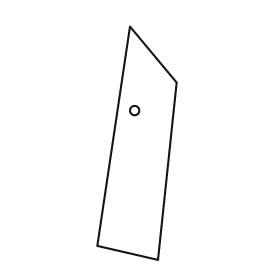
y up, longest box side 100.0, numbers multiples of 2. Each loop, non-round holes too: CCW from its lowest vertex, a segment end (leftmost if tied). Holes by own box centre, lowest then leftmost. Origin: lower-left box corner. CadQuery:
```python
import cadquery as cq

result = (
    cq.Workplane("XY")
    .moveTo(26.0, 0.0)
    .lineTo(34.0, 76.0)
    .lineTo(14.0, 100.0)
    .lineTo(0.0, 6.0)
    .close()
    .moveTo(16.0, 64.0)
    .circle(2.0)
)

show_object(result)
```